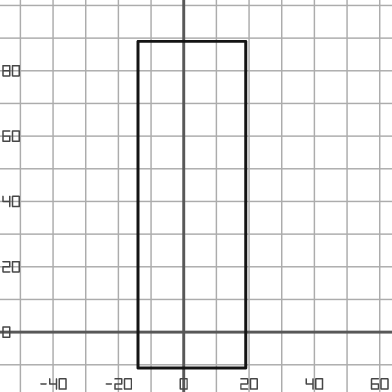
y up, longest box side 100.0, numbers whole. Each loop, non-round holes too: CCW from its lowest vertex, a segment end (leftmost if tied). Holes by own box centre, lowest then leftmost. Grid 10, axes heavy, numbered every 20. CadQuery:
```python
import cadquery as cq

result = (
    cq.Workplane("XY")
    .moveTo(-14.0, -11.0)
    .lineTo(19.0, -11.0)
    .lineTo(19.0, 89.0)
    .lineTo(-14.0, 89.0)
    .close()
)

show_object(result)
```